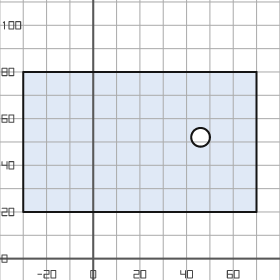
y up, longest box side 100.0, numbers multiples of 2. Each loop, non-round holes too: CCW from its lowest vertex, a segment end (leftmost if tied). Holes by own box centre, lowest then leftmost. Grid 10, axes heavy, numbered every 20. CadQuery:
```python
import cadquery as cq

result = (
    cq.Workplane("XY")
    .moveTo(-30.0, 20.0)
    .lineTo(70.0, 20.0)
    .lineTo(70.0, 80.0)
    .lineTo(-30.0, 80.0)
    .close()
    .moveTo(46.0, 52.0)
    .circle(4.0)
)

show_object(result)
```